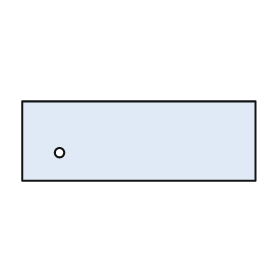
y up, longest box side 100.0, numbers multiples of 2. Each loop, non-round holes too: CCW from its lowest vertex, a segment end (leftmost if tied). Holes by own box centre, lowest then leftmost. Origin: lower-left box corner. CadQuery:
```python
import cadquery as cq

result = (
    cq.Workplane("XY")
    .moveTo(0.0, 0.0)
    .lineTo(100.0, 0.0)
    .lineTo(100.0, 34.0)
    .lineTo(0.0, 34.0)
    .close()
    .moveTo(16.0, 12.0)
    .circle(2.0)
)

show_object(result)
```